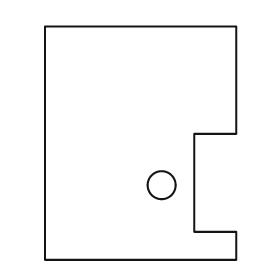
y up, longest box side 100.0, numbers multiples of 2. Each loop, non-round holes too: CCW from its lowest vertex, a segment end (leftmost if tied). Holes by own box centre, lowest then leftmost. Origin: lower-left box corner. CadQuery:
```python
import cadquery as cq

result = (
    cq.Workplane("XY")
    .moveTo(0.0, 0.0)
    .lineTo(82.0, 0.0)
    .lineTo(82.0, 12.0)
    .lineTo(64.0, 12.0)
    .lineTo(64.0, 54.0)
    .lineTo(82.0, 54.0)
    .lineTo(82.0, 100.0)
    .lineTo(0.0, 100.0)
    .close()
    .moveTo(50.0, 32.0)
    .circle(6.0)
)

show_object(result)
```